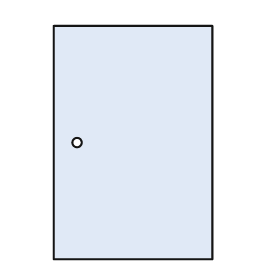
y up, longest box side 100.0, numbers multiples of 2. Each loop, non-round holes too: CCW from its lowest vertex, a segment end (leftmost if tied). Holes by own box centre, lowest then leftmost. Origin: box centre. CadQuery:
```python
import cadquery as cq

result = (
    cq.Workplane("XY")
    .moveTo(-34.0, -50.0)
    .lineTo(34.0, -50.0)
    .lineTo(34.0, 50.0)
    .lineTo(-34.0, 50.0)
    .close()
    .moveTo(-24.0, 0.0)
    .circle(2.0)
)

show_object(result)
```